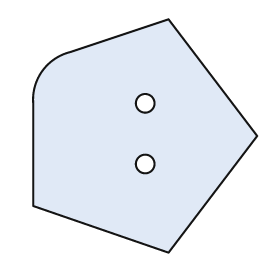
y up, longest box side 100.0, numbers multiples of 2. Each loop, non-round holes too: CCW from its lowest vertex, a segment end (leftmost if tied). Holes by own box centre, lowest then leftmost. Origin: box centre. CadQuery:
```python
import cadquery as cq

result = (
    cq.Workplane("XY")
    .moveTo(10.0, -50.0)
    .lineTo(48.0, 0.0)
    .lineTo(10.0, 50.0)
    .lineTo(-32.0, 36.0)
    .threePointArc((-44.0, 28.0), (-48.0, 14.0))
    .lineTo(-48.0, -30.0)
    .close()
    .moveTo(0.0, -12.0)
    .circle(4.0)
    .moveTo(0.0, 14.0)
    .circle(4.0)
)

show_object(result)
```